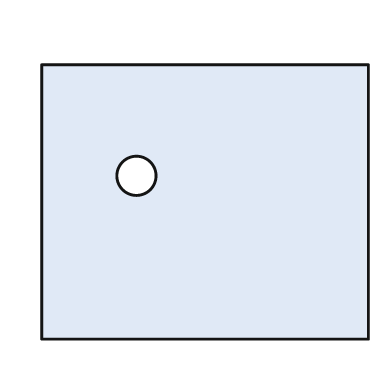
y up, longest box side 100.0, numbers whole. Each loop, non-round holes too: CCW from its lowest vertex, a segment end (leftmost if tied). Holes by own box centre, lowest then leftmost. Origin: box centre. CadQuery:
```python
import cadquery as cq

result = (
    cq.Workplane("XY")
    .moveTo(-50.0, -42.0)
    .lineTo(50.0, -42.0)
    .lineTo(50.0, 42.0)
    .lineTo(-50.0, 42.0)
    .close()
    .moveTo(-21.0, 8.0)
    .circle(6.0)
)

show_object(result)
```